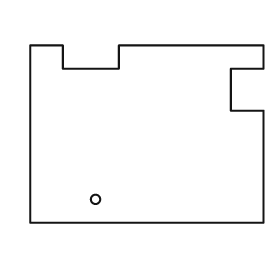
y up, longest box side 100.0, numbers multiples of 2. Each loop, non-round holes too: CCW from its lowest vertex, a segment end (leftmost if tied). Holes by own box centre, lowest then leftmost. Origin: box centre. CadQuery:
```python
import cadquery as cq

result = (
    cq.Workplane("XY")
    .moveTo(-50.0, -38.0)
    .lineTo(50.0, -38.0)
    .lineTo(50.0, 10.0)
    .lineTo(36.0, 10.0)
    .lineTo(36.0, 28.0)
    .lineTo(50.0, 28.0)
    .lineTo(50.0, 38.0)
    .lineTo(-12.0, 38.0)
    .lineTo(-12.0, 28.0)
    .lineTo(-36.0, 28.0)
    .lineTo(-36.0, 38.0)
    .lineTo(-50.0, 38.0)
    .close()
    .moveTo(-22.0, -28.0)
    .circle(2.0)
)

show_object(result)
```